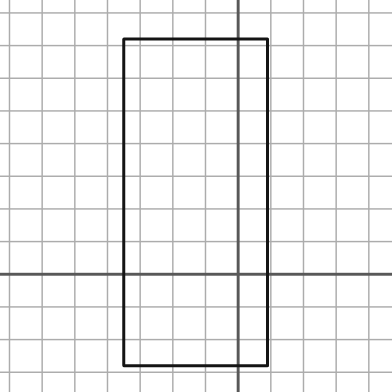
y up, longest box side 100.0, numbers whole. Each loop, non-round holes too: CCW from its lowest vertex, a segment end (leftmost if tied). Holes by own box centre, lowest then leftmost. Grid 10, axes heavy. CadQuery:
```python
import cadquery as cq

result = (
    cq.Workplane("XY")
    .moveTo(-35.0, -28.0)
    .lineTo(9.0, -28.0)
    .lineTo(9.0, 72.0)
    .lineTo(-35.0, 72.0)
    .close()
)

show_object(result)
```